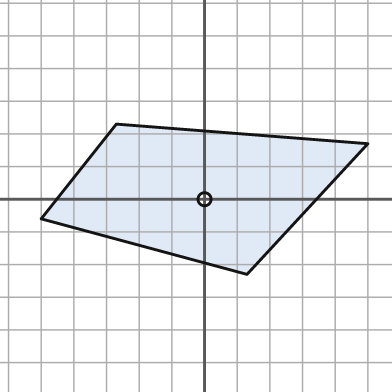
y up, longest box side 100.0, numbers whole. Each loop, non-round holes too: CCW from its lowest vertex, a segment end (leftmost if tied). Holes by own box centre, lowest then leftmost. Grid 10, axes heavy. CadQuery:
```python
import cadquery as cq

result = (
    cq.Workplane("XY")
    .moveTo(13.0, -23.0)
    .lineTo(50.0, 17.0)
    .lineTo(-27.0, 23.0)
    .lineTo(-50.0, -6.0)
    .close()
    .moveTo(0.0, 0.0)
    .circle(2.0)
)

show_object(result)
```